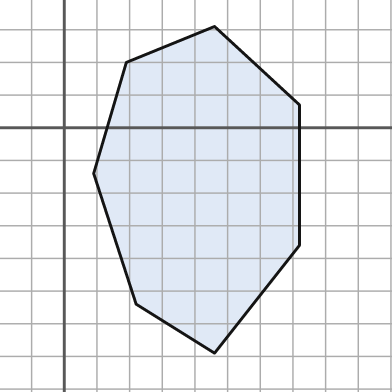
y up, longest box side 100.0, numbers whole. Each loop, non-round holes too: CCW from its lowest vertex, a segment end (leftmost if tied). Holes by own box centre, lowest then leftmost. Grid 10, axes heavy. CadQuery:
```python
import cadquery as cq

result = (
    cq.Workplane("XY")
    .moveTo(46.0, -69.0)
    .lineTo(72.0, -36.0)
    .lineTo(72.0, 7.0)
    .lineTo(46.0, 31.0)
    .lineTo(19.0, 20.0)
    .lineTo(9.0, -14.0)
    .lineTo(22.0, -54.0)
    .close()
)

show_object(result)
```